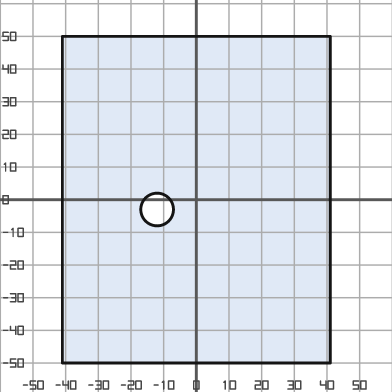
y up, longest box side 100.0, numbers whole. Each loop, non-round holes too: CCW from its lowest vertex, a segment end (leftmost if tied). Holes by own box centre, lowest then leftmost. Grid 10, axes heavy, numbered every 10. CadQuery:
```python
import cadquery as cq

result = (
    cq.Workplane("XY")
    .moveTo(-41.0, -50.0)
    .lineTo(41.0, -50.0)
    .lineTo(41.0, 50.0)
    .lineTo(-41.0, 50.0)
    .close()
    .moveTo(-12.0, -3.0)
    .circle(5.0)
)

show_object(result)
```